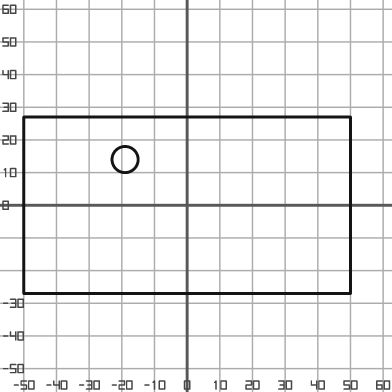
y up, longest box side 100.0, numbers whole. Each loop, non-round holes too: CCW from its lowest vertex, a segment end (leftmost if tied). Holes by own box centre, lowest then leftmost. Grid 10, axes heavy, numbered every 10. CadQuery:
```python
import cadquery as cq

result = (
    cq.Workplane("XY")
    .moveTo(-50.0, -27.0)
    .lineTo(50.0, -27.0)
    .lineTo(50.0, 27.0)
    .lineTo(-50.0, 27.0)
    .close()
    .moveTo(-19.0, 14.0)
    .circle(4.0)
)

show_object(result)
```